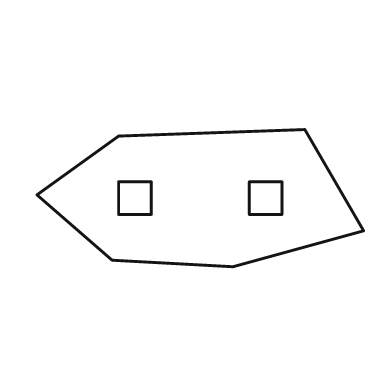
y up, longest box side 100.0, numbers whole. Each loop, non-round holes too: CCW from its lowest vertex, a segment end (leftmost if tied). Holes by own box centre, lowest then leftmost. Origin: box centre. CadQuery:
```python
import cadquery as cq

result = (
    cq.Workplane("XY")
    .moveTo(10.0, -21.0)
    .lineTo(50.0, -10.0)
    .lineTo(32.0, 21.0)
    .lineTo(-25.0, 19.0)
    .lineTo(-50.0, 1.0)
    .lineTo(-27.0, -19.0)
    .close()
    .moveTo(-25.0, -5.0)
    .lineTo(-15.0, -5.0)
    .lineTo(-15.0, 5.0)
    .lineTo(-25.0, 5.0)
    .close()
    .moveTo(15.0, -5.0)
    .lineTo(25.0, -5.0)
    .lineTo(25.0, 5.0)
    .lineTo(15.0, 5.0)
    .close()
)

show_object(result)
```